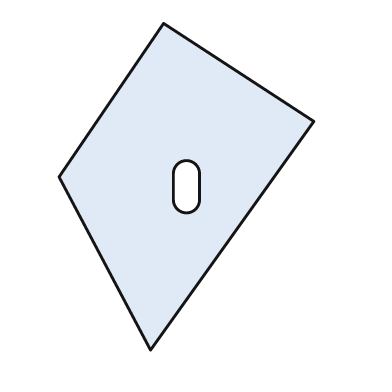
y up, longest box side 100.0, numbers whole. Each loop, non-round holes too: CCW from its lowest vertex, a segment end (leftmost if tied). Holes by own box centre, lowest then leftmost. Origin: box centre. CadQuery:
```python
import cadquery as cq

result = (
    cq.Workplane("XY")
    .moveTo(-11.0, -50.0)
    .lineTo(39.0, 20.0)
    .lineTo(-7.0, 50.0)
    .lineTo(-39.0, 3.0)
    .close()
    .moveTo(-4.0, -4.0)
    .threePointArc((0.0, -8.0), (4.0, -4.0))
    .lineTo(4.0, 4.0)
    .threePointArc((0.0, 8.0), (-4.0, 4.0))
    .close()
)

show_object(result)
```